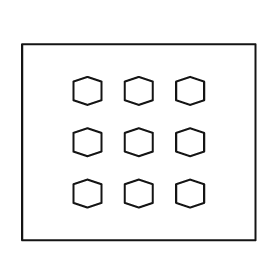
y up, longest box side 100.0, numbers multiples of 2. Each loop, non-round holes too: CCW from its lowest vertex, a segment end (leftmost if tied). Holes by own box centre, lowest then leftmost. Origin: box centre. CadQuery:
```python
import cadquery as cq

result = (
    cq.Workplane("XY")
    .moveTo(-50.0, -42.0)
    .lineTo(50.0, -42.0)
    .lineTo(50.0, 42.0)
    .lineTo(-50.0, 42.0)
    .close()
    .moveTo(-22.0, -28.0)
    .lineTo(-16.0, -26.0)
    .lineTo(-16.0, -18.0)
    .lineTo(-22.0, -16.0)
    .lineTo(-28.0, -18.0)
    .lineTo(-28.0, -26.0)
    .close()
    .moveTo(0.0, -28.0)
    .lineTo(6.0, -26.0)
    .lineTo(6.0, -18.0)
    .lineTo(0.0, -16.0)
    .lineTo(-6.0, -18.0)
    .lineTo(-6.0, -26.0)
    .close()
    .moveTo(22.0, -28.0)
    .lineTo(28.0, -26.0)
    .lineTo(28.0, -18.0)
    .lineTo(22.0, -16.0)
    .lineTo(16.0, -18.0)
    .lineTo(16.0, -26.0)
    .close()
    .moveTo(-22.0, -6.0)
    .lineTo(-16.0, -4.0)
    .lineTo(-16.0, 4.0)
    .lineTo(-22.0, 6.0)
    .lineTo(-28.0, 4.0)
    .lineTo(-28.0, -4.0)
    .close()
    .moveTo(0.0, -6.0)
    .lineTo(6.0, -4.0)
    .lineTo(6.0, 4.0)
    .lineTo(0.0, 6.0)
    .lineTo(-6.0, 4.0)
    .lineTo(-6.0, -4.0)
    .close()
    .moveTo(22.0, -6.0)
    .lineTo(28.0, -4.0)
    .lineTo(28.0, 4.0)
    .lineTo(22.0, 6.0)
    .lineTo(16.0, 4.0)
    .lineTo(16.0, -4.0)
    .close()
    .moveTo(-22.0, 16.0)
    .lineTo(-16.0, 18.0)
    .lineTo(-16.0, 26.0)
    .lineTo(-22.0, 28.0)
    .lineTo(-28.0, 26.0)
    .lineTo(-28.0, 18.0)
    .close()
    .moveTo(0.0, 16.0)
    .lineTo(6.0, 18.0)
    .lineTo(6.0, 26.0)
    .lineTo(0.0, 28.0)
    .lineTo(-6.0, 26.0)
    .lineTo(-6.0, 18.0)
    .close()
    .moveTo(22.0, 16.0)
    .lineTo(28.0, 18.0)
    .lineTo(28.0, 26.0)
    .lineTo(22.0, 28.0)
    .lineTo(16.0, 26.0)
    .lineTo(16.0, 18.0)
    .close()
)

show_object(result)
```